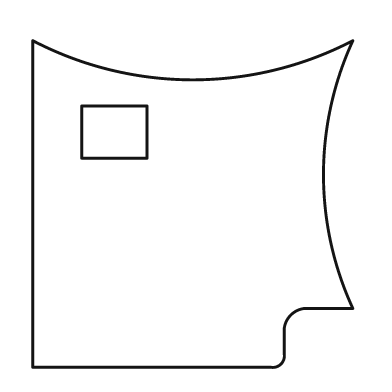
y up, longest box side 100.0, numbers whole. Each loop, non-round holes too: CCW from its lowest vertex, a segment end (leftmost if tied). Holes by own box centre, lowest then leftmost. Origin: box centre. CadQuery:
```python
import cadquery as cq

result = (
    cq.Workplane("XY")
    .moveTo(-49.0, -50.0)
    .lineTo(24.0, -50.0)
    .threePointArc((27.0, -49.0), (28.0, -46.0))
    .lineTo(28.0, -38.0)
    .threePointArc((30.0, -34.0), (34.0, -32.0))
    .lineTo(49.0, -32.0)
    .threePointArc((40.0, 9.0), (49.0, 50.0))
    .threePointArc((0.0, 38.0), (-49.0, 50.0))
    .close()
    .moveTo(-34.0, 14.0)
    .lineTo(-14.0, 14.0)
    .lineTo(-14.0, 30.0)
    .lineTo(-34.0, 30.0)
    .close()
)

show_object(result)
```